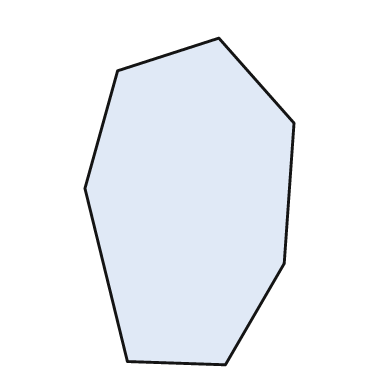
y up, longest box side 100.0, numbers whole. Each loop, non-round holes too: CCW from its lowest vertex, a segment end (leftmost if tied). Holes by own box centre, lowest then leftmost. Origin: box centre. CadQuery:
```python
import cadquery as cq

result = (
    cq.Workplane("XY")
    .moveTo(11.0, -50.0)
    .lineTo(29.0, -19.0)
    .lineTo(32.0, 24.0)
    .lineTo(9.0, 50.0)
    .lineTo(-22.0, 40.0)
    .lineTo(-32.0, 4.0)
    .lineTo(-19.0, -49.0)
    .close()
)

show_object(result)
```